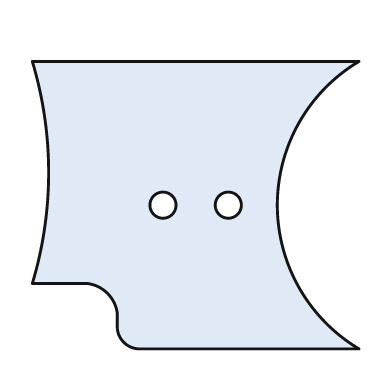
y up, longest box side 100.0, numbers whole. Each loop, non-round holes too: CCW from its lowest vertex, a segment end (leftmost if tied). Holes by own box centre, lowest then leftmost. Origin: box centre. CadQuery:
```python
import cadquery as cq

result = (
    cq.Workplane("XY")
    .moveTo(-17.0, -44.0)
    .lineTo(50.0, -44.0)
    .threePointArc((25.0, 0.0), (50.0, 44.0))
    .lineTo(-50.0, 44.0)
    .threePointArc((-45.0, 10.0), (-50.0, -24.0))
    .lineTo(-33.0, -24.0)
    .threePointArc((-27.0, -27.0), (-24.0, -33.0))
    .lineTo(-24.0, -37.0)
    .threePointArc((-22.0, -42.0), (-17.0, -44.0))
    .close()
    .moveTo(-10.0, 0.0)
    .circle(4.0)
    .moveTo(10.0, 0.0)
    .circle(4.0)
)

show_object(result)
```